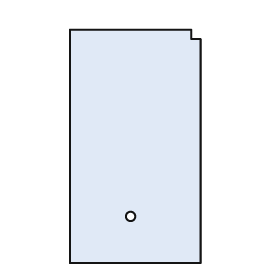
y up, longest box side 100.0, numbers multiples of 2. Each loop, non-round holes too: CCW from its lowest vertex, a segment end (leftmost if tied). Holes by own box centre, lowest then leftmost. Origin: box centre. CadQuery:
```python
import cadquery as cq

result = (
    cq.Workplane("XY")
    .moveTo(-28.0, -50.0)
    .lineTo(28.0, -50.0)
    .lineTo(28.0, 46.0)
    .lineTo(24.0, 46.0)
    .lineTo(24.0, 50.0)
    .lineTo(-28.0, 50.0)
    .close()
    .moveTo(-2.0, -30.0)
    .circle(2.0)
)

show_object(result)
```